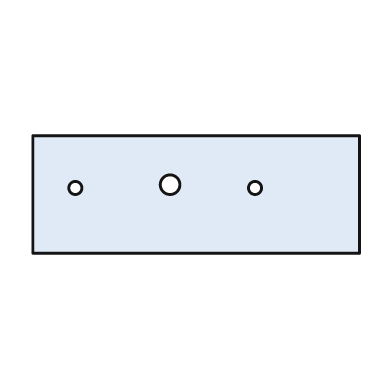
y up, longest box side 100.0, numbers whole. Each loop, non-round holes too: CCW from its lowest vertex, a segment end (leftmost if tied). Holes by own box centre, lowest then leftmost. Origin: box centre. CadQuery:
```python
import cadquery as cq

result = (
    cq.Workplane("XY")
    .moveTo(-50.0, -18.0)
    .lineTo(50.0, -18.0)
    .lineTo(50.0, 18.0)
    .lineTo(-50.0, 18.0)
    .close()
    .moveTo(-37.0, 2.0)
    .circle(2.0)
    .moveTo(18.0, 2.0)
    .circle(2.0)
    .moveTo(-8.0, 3.0)
    .circle(3.0)
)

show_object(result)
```